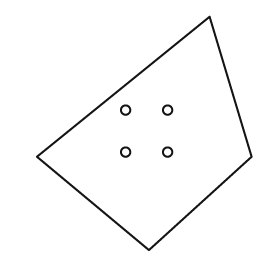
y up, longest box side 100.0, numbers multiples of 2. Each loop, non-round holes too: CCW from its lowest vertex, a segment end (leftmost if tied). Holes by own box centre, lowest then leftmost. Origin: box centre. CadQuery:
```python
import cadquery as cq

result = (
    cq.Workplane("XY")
    .moveTo(2.0, -50.0)
    .lineTo(46.0, -10.0)
    .lineTo(28.0, 50.0)
    .lineTo(-46.0, -10.0)
    .close()
    .moveTo(-8.0, -8.0)
    .circle(2.0)
    .moveTo(10.0, -8.0)
    .circle(2.0)
    .moveTo(-8.0, 10.0)
    .circle(2.0)
    .moveTo(10.0, 10.0)
    .circle(2.0)
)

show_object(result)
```